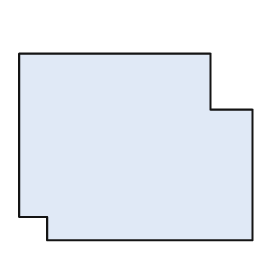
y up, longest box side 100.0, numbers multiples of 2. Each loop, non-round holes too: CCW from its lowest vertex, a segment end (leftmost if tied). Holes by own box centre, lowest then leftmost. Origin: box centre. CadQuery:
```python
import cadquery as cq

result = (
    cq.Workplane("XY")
    .moveTo(-38.0, -40.0)
    .lineTo(50.0, -40.0)
    .lineTo(50.0, 16.0)
    .lineTo(32.0, 16.0)
    .lineTo(32.0, 40.0)
    .lineTo(-50.0, 40.0)
    .lineTo(-50.0, -30.0)
    .lineTo(-38.0, -30.0)
    .close()
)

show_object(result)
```